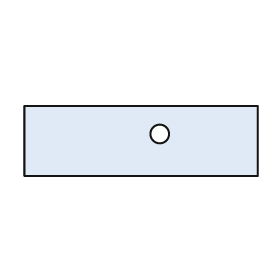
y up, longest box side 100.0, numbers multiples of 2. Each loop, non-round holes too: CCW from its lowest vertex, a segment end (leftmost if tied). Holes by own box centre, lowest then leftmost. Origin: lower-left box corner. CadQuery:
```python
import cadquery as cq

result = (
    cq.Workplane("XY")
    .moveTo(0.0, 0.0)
    .lineTo(100.0, 0.0)
    .lineTo(100.0, 30.0)
    .lineTo(0.0, 30.0)
    .close()
    .moveTo(58.0, 18.0)
    .circle(4.0)
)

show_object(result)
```